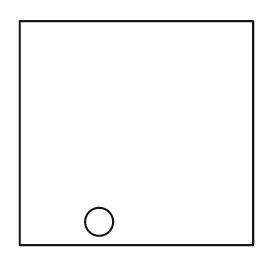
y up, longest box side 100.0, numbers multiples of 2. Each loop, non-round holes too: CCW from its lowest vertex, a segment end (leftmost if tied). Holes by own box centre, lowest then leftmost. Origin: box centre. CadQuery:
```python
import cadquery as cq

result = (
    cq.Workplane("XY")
    .moveTo(-50.0, -48.0)
    .lineTo(50.0, -48.0)
    .lineTo(50.0, 48.0)
    .lineTo(-50.0, 48.0)
    .close()
    .moveTo(-16.0, -38.0)
    .circle(6.0)
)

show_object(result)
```